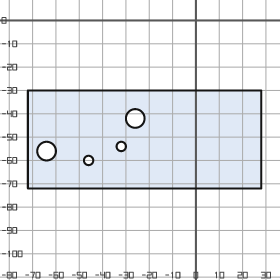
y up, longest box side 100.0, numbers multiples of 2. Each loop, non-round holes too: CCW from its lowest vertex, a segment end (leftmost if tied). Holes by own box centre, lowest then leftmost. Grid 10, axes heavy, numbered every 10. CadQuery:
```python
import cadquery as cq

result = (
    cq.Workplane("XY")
    .moveTo(-72.0, -72.0)
    .lineTo(28.0, -72.0)
    .lineTo(28.0, -30.0)
    .lineTo(-72.0, -30.0)
    .close()
    .moveTo(-46.0, -60.0)
    .circle(2.0)
    .moveTo(-64.0, -56.0)
    .circle(4.0)
    .moveTo(-32.0, -54.0)
    .circle(2.0)
    .moveTo(-26.0, -42.0)
    .circle(4.0)
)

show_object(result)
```